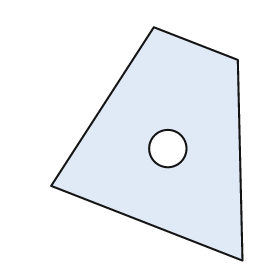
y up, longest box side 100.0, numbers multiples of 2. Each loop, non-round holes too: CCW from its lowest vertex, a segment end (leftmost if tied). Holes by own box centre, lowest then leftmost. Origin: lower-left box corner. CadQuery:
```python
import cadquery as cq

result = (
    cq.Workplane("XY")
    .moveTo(82.0, 0.0)
    .lineTo(80.0, 86.0)
    .lineTo(44.0, 100.0)
    .lineTo(0.0, 32.0)
    .close()
    .moveTo(50.0, 48.0)
    .circle(8.0)
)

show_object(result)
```